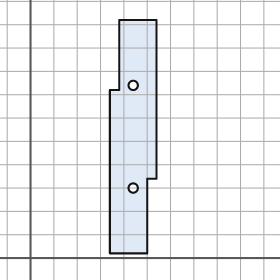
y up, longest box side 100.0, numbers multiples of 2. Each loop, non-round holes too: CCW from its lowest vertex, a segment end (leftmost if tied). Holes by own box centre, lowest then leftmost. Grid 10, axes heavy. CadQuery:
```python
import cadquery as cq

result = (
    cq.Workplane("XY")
    .moveTo(34.0, 2.0)
    .lineTo(50.0, 2.0)
    .lineTo(50.0, 34.0)
    .lineTo(54.0, 34.0)
    .lineTo(54.0, 102.0)
    .lineTo(38.0, 102.0)
    .lineTo(38.0, 72.0)
    .lineTo(34.0, 72.0)
    .close()
    .moveTo(44.0, 30.0)
    .circle(2.0)
    .moveTo(44.0, 74.0)
    .circle(2.0)
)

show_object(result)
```